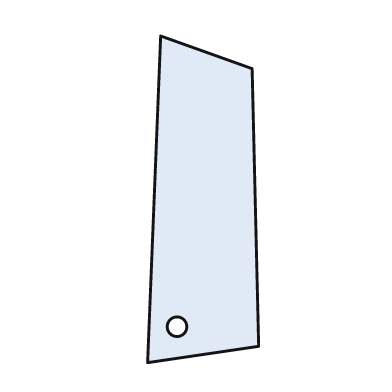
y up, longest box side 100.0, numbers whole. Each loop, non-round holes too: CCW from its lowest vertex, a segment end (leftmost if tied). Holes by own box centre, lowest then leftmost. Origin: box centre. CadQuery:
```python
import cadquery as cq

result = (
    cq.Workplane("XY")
    .moveTo(-17.0, -50.0)
    .lineTo(17.0, -45.0)
    .lineTo(15.0, 40.0)
    .lineTo(-13.0, 50.0)
    .close()
    .moveTo(-8.0, -39.0)
    .circle(3.0)
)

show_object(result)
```